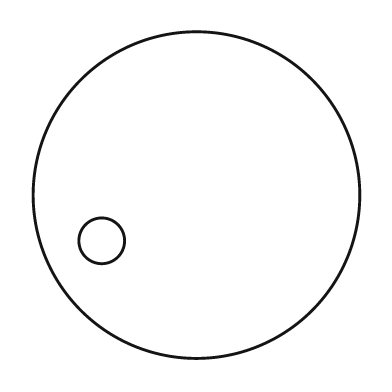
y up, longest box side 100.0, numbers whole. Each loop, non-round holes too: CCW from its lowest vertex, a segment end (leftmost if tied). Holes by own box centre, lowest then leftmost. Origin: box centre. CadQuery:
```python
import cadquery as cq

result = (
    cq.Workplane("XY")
    .moveTo(0.0, 0.0)
    .circle(50.0)
    .moveTo(-29.0, -14.0)
    .circle(7.0)
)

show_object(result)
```